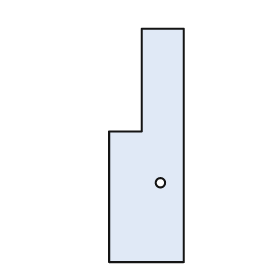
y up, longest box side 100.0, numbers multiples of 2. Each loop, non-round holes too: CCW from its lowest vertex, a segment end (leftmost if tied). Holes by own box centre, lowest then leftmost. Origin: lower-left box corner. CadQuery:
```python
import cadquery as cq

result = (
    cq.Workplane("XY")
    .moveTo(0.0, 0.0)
    .lineTo(32.0, 0.0)
    .lineTo(32.0, 100.0)
    .lineTo(14.0, 100.0)
    .lineTo(14.0, 56.0)
    .lineTo(0.0, 56.0)
    .close()
    .moveTo(22.0, 34.0)
    .circle(2.0)
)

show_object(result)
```